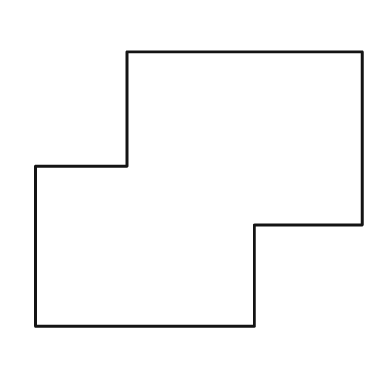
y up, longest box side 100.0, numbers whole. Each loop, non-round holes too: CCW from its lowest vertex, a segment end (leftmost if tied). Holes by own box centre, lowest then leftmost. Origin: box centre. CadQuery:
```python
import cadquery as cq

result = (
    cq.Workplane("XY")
    .moveTo(-50.0, -42.0)
    .lineTo(17.0, -42.0)
    .lineTo(17.0, -11.0)
    .lineTo(50.0, -11.0)
    .lineTo(50.0, 42.0)
    .lineTo(-22.0, 42.0)
    .lineTo(-22.0, 7.0)
    .lineTo(-50.0, 7.0)
    .close()
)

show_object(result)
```